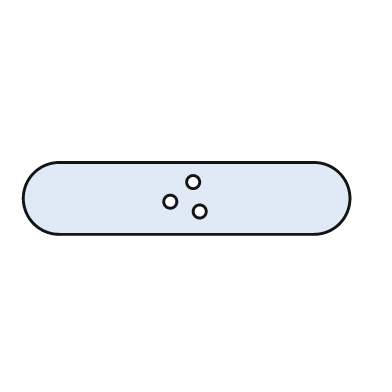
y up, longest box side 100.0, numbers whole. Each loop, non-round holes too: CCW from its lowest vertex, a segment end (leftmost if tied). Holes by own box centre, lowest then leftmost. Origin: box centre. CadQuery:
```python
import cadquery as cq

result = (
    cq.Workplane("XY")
    .moveTo(-39.0, -11.0)
    .lineTo(39.0, -11.0)
    .threePointArc((50.0, 0.0), (39.0, 11.0))
    .lineTo(-39.0, 11.0)
    .threePointArc((-50.0, 0.0), (-39.0, -11.0))
    .close()
    .moveTo(4.0, -4.0)
    .circle(2.0)
    .moveTo(-5.0, -1.0)
    .circle(2.0)
    .moveTo(2.0, 5.0)
    .circle(2.0)
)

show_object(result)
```